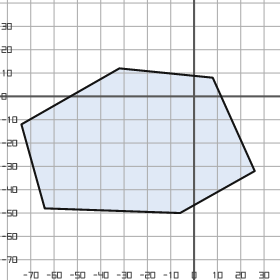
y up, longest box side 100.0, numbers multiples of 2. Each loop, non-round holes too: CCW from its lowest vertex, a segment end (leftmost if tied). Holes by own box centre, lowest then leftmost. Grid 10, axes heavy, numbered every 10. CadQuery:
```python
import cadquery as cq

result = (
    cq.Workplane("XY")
    .moveTo(-6.0, -50.0)
    .lineTo(26.0, -32.0)
    .lineTo(8.0, 8.0)
    .lineTo(-32.0, 12.0)
    .lineTo(-74.0, -12.0)
    .lineTo(-64.0, -48.0)
    .close()
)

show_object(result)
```